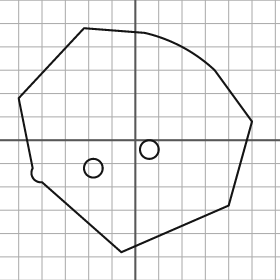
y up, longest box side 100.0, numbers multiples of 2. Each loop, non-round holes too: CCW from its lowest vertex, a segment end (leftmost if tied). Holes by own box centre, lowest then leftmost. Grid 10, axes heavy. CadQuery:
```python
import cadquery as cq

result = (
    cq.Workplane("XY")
    .moveTo(-6.0, -48.0)
    .lineTo(40.0, -28.0)
    .lineTo(50.0, 8.0)
    .lineTo(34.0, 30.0)
    .threePointArc((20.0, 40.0), (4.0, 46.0))
    .lineTo(-22.0, 48.0)
    .lineTo(-50.0, 18.0)
    .lineTo(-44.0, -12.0)
    .threePointArc((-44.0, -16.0), (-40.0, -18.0))
    .close()
    .moveTo(-18.0, -12.0)
    .circle(4.0)
    .moveTo(6.0, -4.0)
    .circle(4.0)
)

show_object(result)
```